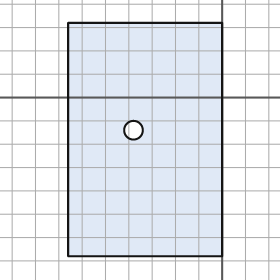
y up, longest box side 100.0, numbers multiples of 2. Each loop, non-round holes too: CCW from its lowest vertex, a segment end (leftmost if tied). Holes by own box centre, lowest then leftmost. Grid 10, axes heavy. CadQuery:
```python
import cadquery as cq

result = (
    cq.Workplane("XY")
    .moveTo(-66.0, -68.0)
    .lineTo(0.0, -68.0)
    .lineTo(0.0, 32.0)
    .lineTo(-66.0, 32.0)
    .close()
    .moveTo(-38.0, -14.0)
    .circle(4.0)
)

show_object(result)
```